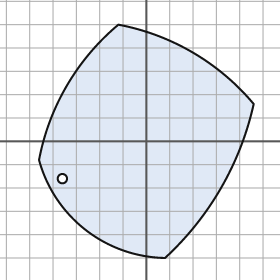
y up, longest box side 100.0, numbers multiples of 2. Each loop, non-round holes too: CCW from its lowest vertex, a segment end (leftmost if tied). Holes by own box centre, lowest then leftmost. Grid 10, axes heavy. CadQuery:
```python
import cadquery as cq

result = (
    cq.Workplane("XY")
    .moveTo(8.0, -50.0)
    .threePointArc((32.0, -20.0), (46.0, 16.0))
    .threePointArc((20.0, 38.0), (-12.0, 50.0))
    .threePointArc((-34.0, 24.0), (-46.0, -8.0))
    .threePointArc((-26.0, -38.0), (8.0, -50.0))
    .close()
    .moveTo(-36.0, -16.0)
    .circle(2.0)
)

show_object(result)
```